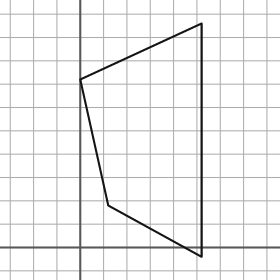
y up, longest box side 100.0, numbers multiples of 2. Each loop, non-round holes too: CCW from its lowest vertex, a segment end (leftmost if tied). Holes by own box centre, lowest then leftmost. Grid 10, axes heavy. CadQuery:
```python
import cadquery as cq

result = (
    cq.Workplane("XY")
    .moveTo(52.0, -4.0)
    .lineTo(52.0, 96.0)
    .lineTo(0.0, 72.0)
    .lineTo(12.0, 18.0)
    .close()
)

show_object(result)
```